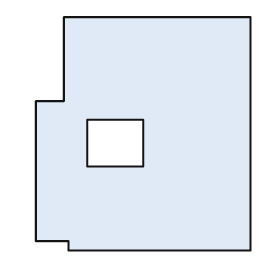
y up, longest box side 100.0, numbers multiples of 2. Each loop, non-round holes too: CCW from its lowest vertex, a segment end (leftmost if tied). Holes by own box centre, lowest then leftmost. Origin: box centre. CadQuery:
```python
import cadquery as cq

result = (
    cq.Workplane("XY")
    .moveTo(-32.0, -50.0)
    .lineTo(46.0, -50.0)
    .lineTo(46.0, 50.0)
    .lineTo(-34.0, 50.0)
    .lineTo(-34.0, 14.0)
    .lineTo(-46.0, 14.0)
    .lineTo(-46.0, -46.0)
    .lineTo(-32.0, -46.0)
    .close()
    .moveTo(-24.0, -14.0)
    .lineTo(0.0, -14.0)
    .lineTo(0.0, 6.0)
    .lineTo(-24.0, 6.0)
    .close()
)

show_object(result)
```